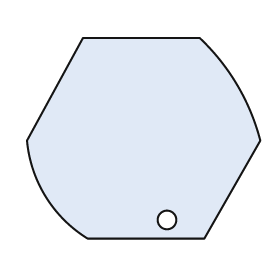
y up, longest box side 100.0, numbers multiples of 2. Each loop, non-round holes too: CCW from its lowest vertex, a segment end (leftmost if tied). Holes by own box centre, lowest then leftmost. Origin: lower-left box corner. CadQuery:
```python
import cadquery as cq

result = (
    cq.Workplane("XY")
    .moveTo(26.0, 0.0)
    .lineTo(76.0, 0.0)
    .lineTo(100.0, 42.0)
    .threePointArc((90.0, 66.0), (74.0, 86.0))
    .lineTo(24.0, 86.0)
    .lineTo(0.0, 42.0)
    .threePointArc((8.0, 18.0), (26.0, 0.0))
    .close()
    .moveTo(60.0, 8.0)
    .circle(4.0)
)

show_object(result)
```